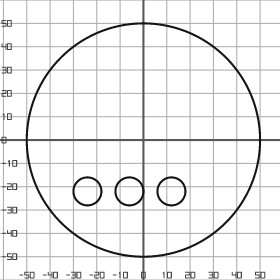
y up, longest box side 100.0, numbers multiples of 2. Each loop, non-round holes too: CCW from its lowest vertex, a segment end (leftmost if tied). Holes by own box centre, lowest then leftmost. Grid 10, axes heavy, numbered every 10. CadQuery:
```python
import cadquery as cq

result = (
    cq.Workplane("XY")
    .moveTo(0.0, 0.0)
    .circle(50.0)
    .moveTo(-24.0, -22.0)
    .circle(6.0)
    .moveTo(-6.0, -22.0)
    .circle(6.0)
    .moveTo(12.0, -22.0)
    .circle(6.0)
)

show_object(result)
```